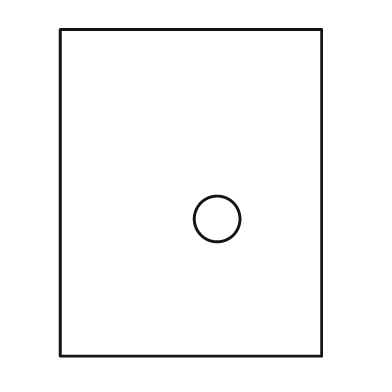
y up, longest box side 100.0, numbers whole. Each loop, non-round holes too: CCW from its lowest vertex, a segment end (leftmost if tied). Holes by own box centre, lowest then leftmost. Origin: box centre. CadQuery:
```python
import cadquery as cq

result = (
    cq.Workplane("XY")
    .moveTo(-40.0, -50.0)
    .lineTo(40.0, -50.0)
    .lineTo(40.0, 50.0)
    .lineTo(-40.0, 50.0)
    .close()
    .moveTo(8.0, -8.0)
    .circle(7.0)
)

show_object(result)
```